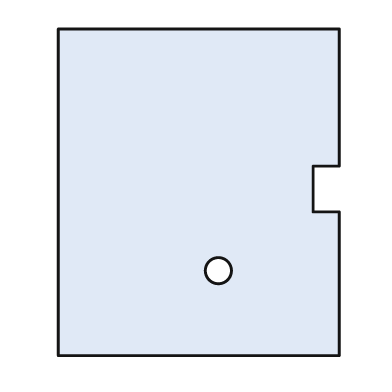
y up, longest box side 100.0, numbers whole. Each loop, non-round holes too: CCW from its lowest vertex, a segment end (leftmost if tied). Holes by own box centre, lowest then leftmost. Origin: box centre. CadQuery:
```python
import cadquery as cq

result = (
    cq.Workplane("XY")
    .moveTo(-43.0, -50.0)
    .lineTo(43.0, -50.0)
    .lineTo(43.0, -6.0)
    .lineTo(35.0, -6.0)
    .lineTo(35.0, 8.0)
    .lineTo(43.0, 8.0)
    .lineTo(43.0, 50.0)
    .lineTo(-43.0, 50.0)
    .close()
    .moveTo(6.0, -24.0)
    .circle(4.0)
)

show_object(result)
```